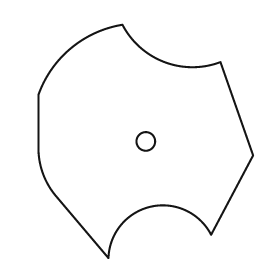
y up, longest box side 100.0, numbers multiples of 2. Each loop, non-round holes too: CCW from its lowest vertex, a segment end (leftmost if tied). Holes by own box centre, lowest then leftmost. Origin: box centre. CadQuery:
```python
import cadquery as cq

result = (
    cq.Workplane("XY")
    .moveTo(-16.0, -50.0)
    .threePointArc((2.0, -28.0), (28.0, -40.0))
    .lineTo(46.0, -6.0)
    .lineTo(32.0, 34.0)
    .threePointArc((8.0, 34.0), (-10.0, 50.0))
    .threePointArc((-32.0, 40.0), (-46.0, 20.0))
    .lineTo(-46.0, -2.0)
    .threePointArc((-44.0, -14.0), (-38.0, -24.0))
    .close()
    .moveTo(0.0, 0.0)
    .circle(4.0)
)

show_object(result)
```